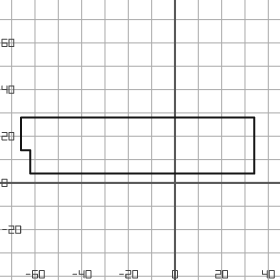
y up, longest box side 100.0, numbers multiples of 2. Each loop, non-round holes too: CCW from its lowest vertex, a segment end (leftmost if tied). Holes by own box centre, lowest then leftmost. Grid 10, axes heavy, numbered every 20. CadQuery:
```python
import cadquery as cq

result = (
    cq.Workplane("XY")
    .moveTo(-62.0, 4.0)
    .lineTo(34.0, 4.0)
    .lineTo(34.0, 28.0)
    .lineTo(-66.0, 28.0)
    .lineTo(-66.0, 14.0)
    .lineTo(-62.0, 14.0)
    .close()
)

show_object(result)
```